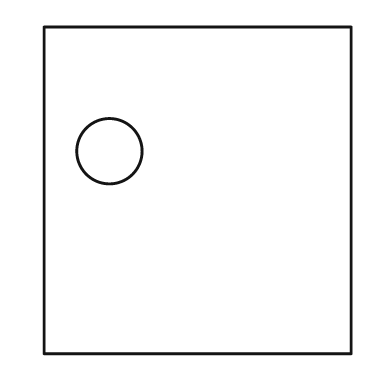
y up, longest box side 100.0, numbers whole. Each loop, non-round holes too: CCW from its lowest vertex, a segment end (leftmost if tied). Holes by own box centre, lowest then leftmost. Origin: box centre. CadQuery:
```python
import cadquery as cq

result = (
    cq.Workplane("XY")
    .moveTo(-47.0, -50.0)
    .lineTo(47.0, -50.0)
    .lineTo(47.0, 50.0)
    .lineTo(-47.0, 50.0)
    .close()
    .moveTo(-27.0, 12.0)
    .circle(10.0)
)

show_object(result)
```